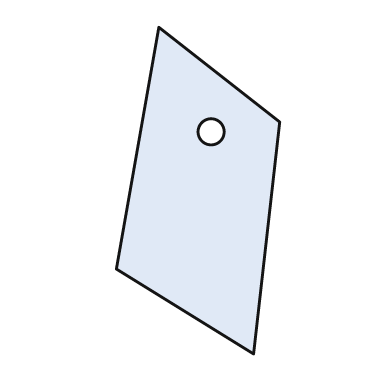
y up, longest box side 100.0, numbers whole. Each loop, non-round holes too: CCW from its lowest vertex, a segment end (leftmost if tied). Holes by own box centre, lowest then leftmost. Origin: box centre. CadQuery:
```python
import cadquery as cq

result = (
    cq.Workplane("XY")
    .moveTo(17.0, -50.0)
    .lineTo(25.0, 21.0)
    .lineTo(-12.0, 50.0)
    .lineTo(-25.0, -24.0)
    .close()
    .moveTo(4.0, 18.0)
    .circle(4.0)
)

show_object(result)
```